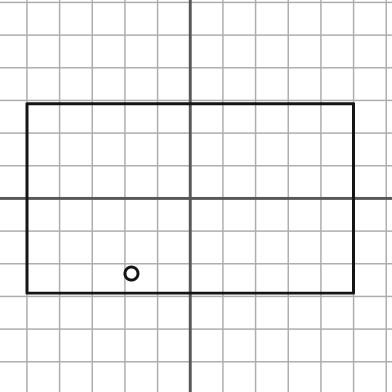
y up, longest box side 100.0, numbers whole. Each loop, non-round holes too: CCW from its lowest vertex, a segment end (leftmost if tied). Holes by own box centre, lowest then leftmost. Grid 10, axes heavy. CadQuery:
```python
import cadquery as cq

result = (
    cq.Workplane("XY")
    .moveTo(-50.0, -29.0)
    .lineTo(50.0, -29.0)
    .lineTo(50.0, 29.0)
    .lineTo(-50.0, 29.0)
    .close()
    .moveTo(-18.0, -23.0)
    .circle(2.0)
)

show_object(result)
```